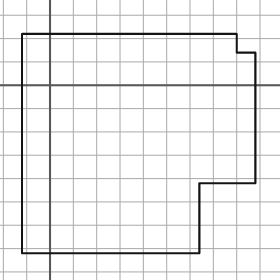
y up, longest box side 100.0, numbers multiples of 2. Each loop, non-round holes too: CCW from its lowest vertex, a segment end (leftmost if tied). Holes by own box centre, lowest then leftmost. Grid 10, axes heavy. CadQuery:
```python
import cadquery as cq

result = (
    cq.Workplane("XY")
    .moveTo(-12.0, -72.0)
    .lineTo(64.0, -72.0)
    .lineTo(64.0, -42.0)
    .lineTo(88.0, -42.0)
    .lineTo(88.0, 14.0)
    .lineTo(80.0, 14.0)
    .lineTo(80.0, 22.0)
    .lineTo(-12.0, 22.0)
    .close()
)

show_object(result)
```